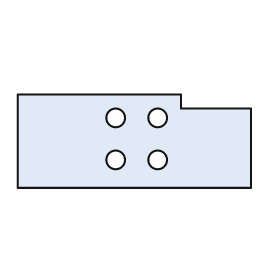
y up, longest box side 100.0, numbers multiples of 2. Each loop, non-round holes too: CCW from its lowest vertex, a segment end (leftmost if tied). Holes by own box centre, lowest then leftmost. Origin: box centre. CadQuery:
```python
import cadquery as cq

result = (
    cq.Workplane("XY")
    .moveTo(-50.0, -20.0)
    .lineTo(50.0, -20.0)
    .lineTo(50.0, 14.0)
    .lineTo(20.0, 14.0)
    .lineTo(20.0, 20.0)
    .lineTo(-50.0, 20.0)
    .close()
    .moveTo(-8.0, -8.0)
    .circle(4.0)
    .moveTo(10.0, -8.0)
    .circle(4.0)
    .moveTo(-8.0, 10.0)
    .circle(4.0)
    .moveTo(10.0, 10.0)
    .circle(4.0)
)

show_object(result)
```